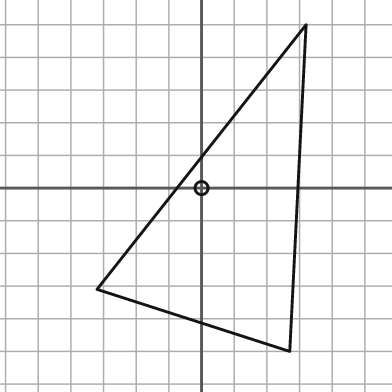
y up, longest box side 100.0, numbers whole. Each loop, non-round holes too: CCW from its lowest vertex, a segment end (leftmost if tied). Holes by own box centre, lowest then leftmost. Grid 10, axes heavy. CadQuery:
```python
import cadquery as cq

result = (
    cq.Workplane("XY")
    .moveTo(27.0, -50.0)
    .lineTo(32.0, 50.0)
    .lineTo(-32.0, -31.0)
    .close()
    .moveTo(0.0, 0.0)
    .circle(2.0)
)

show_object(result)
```